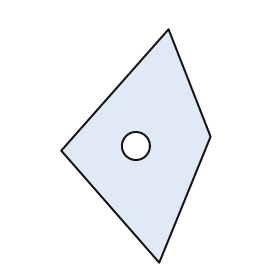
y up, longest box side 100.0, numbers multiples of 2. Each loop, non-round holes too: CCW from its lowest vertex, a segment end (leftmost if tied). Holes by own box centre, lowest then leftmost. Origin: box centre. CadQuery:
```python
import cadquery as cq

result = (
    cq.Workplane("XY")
    .moveTo(10.0, -50.0)
    .lineTo(32.0, 4.0)
    .lineTo(14.0, 50.0)
    .lineTo(-32.0, -2.0)
    .close()
    .moveTo(0.0, 0.0)
    .circle(6.0)
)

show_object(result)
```